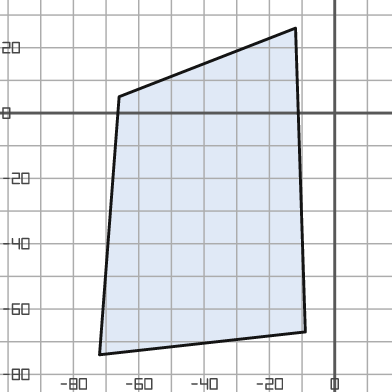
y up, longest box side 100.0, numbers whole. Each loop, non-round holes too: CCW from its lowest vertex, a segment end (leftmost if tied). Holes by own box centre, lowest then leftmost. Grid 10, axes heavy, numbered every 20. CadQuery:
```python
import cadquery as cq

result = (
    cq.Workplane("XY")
    .moveTo(-72.0, -74.0)
    .lineTo(-9.0, -67.0)
    .lineTo(-12.0, 26.0)
    .lineTo(-66.0, 5.0)
    .close()
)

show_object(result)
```